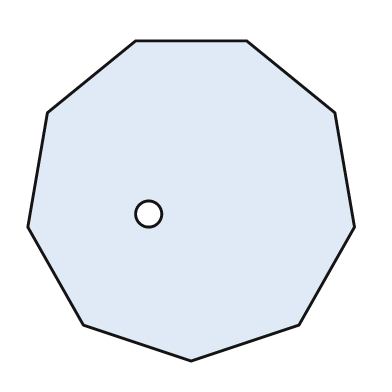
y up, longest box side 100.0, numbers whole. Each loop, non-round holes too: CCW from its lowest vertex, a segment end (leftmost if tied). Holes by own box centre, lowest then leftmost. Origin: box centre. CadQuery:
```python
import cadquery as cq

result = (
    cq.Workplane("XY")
    .moveTo(0.0, -49.0)
    .lineTo(33.0, -38.0)
    .lineTo(50.0, -8.0)
    .lineTo(44.0, 27.0)
    .lineTo(17.0, 49.0)
    .lineTo(-17.0, 49.0)
    .lineTo(-44.0, 27.0)
    .lineTo(-50.0, -8.0)
    .lineTo(-33.0, -38.0)
    .close()
    .moveTo(-13.0, -4.0)
    .circle(4.0)
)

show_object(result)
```